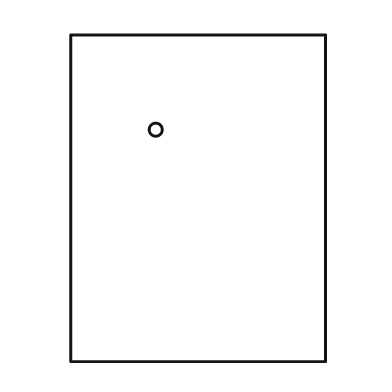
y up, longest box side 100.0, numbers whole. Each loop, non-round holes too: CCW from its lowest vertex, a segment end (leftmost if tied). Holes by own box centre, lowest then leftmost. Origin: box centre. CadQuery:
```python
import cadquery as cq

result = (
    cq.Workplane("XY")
    .moveTo(-39.0, -50.0)
    .lineTo(39.0, -50.0)
    .lineTo(39.0, 50.0)
    .lineTo(-39.0, 50.0)
    .close()
    .moveTo(-13.0, 21.0)
    .circle(2.0)
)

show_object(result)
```